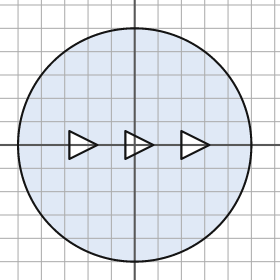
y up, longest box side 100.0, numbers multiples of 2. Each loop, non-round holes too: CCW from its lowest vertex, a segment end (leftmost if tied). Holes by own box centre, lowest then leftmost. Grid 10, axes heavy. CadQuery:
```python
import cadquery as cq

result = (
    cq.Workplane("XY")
    .moveTo(0.0, 0.0)
    .circle(50.0)
    .moveTo(-28.0, -6.0)
    .lineTo(-16.0, 0.0)
    .lineTo(-28.0, 6.0)
    .close()
    .moveTo(-4.0, -6.0)
    .lineTo(8.0, 0.0)
    .lineTo(-4.0, 6.0)
    .close()
    .moveTo(20.0, -6.0)
    .lineTo(32.0, 0.0)
    .lineTo(20.0, 6.0)
    .close()
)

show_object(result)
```